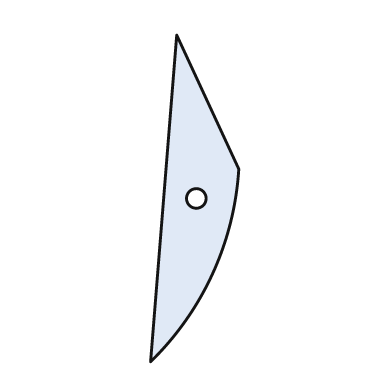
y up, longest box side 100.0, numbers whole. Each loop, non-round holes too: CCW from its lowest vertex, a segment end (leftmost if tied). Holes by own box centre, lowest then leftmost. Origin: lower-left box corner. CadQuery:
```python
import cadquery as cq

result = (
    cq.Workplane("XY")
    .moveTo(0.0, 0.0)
    .threePointArc((19.0, 27.0), (27.0, 59.0))
    .lineTo(8.0, 100.0)
    .close()
    .moveTo(14.0, 50.0)
    .circle(3.0)
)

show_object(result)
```